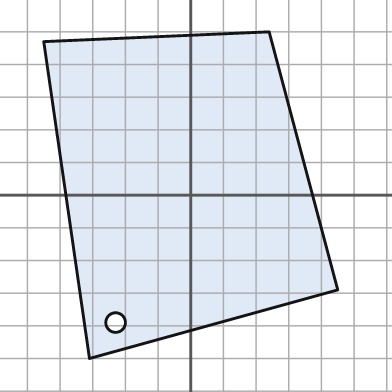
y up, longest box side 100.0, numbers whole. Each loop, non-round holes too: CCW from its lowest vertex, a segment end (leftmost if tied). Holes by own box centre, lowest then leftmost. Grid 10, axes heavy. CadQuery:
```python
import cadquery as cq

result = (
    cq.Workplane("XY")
    .moveTo(-31.0, -50.0)
    .lineTo(45.0, -29.0)
    .lineTo(24.0, 50.0)
    .lineTo(-45.0, 47.0)
    .close()
    .moveTo(-23.0, -39.0)
    .circle(3.0)
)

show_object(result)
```